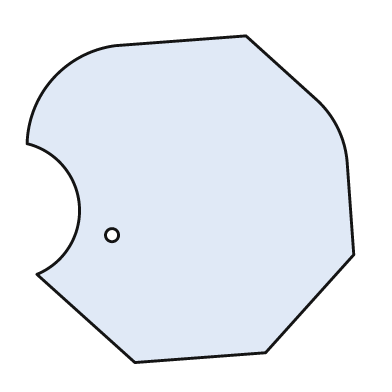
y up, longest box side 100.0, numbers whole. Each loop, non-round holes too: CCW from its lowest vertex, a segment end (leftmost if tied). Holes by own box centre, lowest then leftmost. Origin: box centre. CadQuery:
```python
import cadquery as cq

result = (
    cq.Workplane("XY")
    .moveTo(-17.0, -50.0)
    .lineTo(23.0, -47.0)
    .lineTo(50.0, -17.0)
    .lineTo(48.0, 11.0)
    .threePointArc((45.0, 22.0), (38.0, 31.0))
    .lineTo(17.0, 50.0)
    .lineTo(-23.0, 47.0)
    .threePointArc((-42.0, 37.0), (-50.0, 17.0))
    .threePointArc((-34.0, -2.0), (-47.0, -23.0))
    .close()
    .moveTo(-24.0, -11.0)
    .circle(2.0)
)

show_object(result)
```